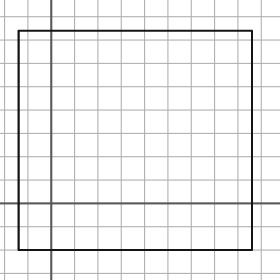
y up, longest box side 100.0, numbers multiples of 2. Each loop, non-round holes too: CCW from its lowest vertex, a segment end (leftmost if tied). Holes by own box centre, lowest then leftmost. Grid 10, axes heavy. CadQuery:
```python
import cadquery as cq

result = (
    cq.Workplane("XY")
    .moveTo(-14.0, -20.0)
    .lineTo(86.0, -20.0)
    .lineTo(86.0, 74.0)
    .lineTo(-14.0, 74.0)
    .close()
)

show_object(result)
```